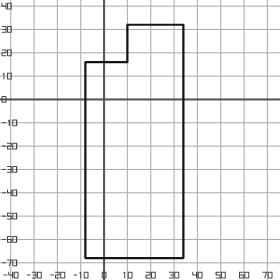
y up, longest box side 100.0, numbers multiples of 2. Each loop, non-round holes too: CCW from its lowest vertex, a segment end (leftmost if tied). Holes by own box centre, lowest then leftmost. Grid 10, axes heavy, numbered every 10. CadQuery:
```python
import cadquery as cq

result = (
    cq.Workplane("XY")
    .moveTo(-8.0, -68.0)
    .lineTo(34.0, -68.0)
    .lineTo(34.0, 32.0)
    .lineTo(10.0, 32.0)
    .lineTo(10.0, 16.0)
    .lineTo(-8.0, 16.0)
    .close()
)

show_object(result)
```